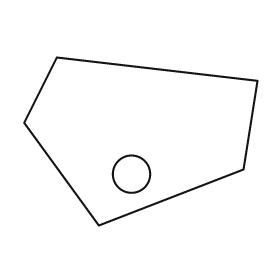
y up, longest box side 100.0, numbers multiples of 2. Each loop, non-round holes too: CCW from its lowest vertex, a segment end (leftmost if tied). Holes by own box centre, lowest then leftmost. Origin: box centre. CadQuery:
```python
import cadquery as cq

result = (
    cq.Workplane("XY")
    .moveTo(-18.0, -36.0)
    .lineTo(44.0, -12.0)
    .lineTo(50.0, 26.0)
    .lineTo(-36.0, 36.0)
    .lineTo(-50.0, 8.0)
    .close()
    .moveTo(-4.0, -14.0)
    .circle(8.0)
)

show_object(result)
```